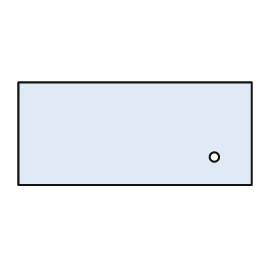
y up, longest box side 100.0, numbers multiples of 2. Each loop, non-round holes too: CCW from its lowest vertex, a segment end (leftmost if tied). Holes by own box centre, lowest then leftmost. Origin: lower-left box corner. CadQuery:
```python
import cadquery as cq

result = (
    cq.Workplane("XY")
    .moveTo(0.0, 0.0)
    .lineTo(100.0, 0.0)
    .lineTo(100.0, 44.0)
    .lineTo(0.0, 44.0)
    .close()
    .moveTo(84.0, 12.0)
    .circle(2.0)
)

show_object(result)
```